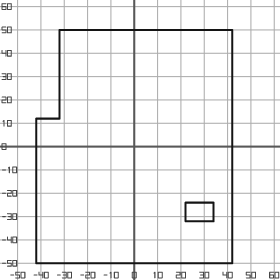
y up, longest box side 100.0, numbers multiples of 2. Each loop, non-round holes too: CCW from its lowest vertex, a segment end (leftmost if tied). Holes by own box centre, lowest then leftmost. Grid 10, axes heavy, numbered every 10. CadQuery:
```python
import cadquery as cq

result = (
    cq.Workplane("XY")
    .moveTo(-42.0, -50.0)
    .lineTo(42.0, -50.0)
    .lineTo(42.0, 50.0)
    .lineTo(-32.0, 50.0)
    .lineTo(-32.0, 12.0)
    .lineTo(-42.0, 12.0)
    .close()
    .moveTo(22.0, -32.0)
    .lineTo(34.0, -32.0)
    .lineTo(34.0, -24.0)
    .lineTo(22.0, -24.0)
    .close()
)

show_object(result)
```